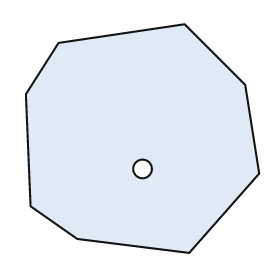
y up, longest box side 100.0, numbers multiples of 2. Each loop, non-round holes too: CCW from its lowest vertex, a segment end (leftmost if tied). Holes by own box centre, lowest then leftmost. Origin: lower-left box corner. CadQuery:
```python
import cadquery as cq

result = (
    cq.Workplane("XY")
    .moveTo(70.0, 0.0)
    .lineTo(100.0, 34.0)
    .lineTo(94.0, 72.0)
    .lineTo(68.0, 98.0)
    .lineTo(14.0, 90.0)
    .lineTo(0.0, 68.0)
    .lineTo(2.0, 20.0)
    .lineTo(22.0, 6.0)
    .close()
    .moveTo(50.0, 36.0)
    .circle(4.0)
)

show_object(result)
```